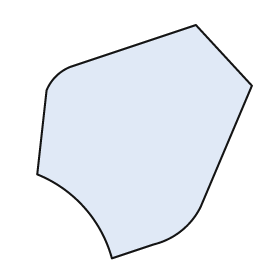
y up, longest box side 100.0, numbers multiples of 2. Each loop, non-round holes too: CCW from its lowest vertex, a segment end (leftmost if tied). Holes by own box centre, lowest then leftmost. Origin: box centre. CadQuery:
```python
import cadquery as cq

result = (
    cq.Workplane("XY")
    .moveTo(-14.0, -50.0)
    .lineTo(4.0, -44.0)
    .threePointArc((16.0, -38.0), (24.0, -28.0))
    .lineTo(46.0, 24.0)
    .lineTo(22.0, 50.0)
    .lineTo(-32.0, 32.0)
    .threePointArc((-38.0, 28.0), (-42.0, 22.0))
    .lineTo(-46.0, -14.0)
    .threePointArc((-26.0, -28.0), (-14.0, -50.0))
    .close()
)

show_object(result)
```